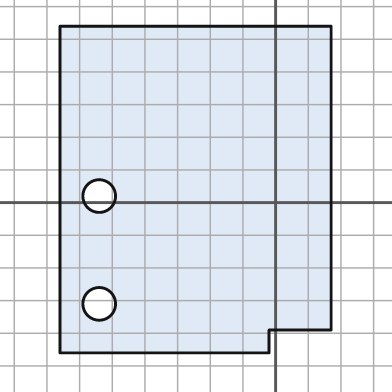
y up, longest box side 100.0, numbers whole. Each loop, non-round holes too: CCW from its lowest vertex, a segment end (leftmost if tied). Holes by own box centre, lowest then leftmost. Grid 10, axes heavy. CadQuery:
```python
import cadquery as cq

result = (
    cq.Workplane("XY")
    .moveTo(-66.0, -46.0)
    .lineTo(-2.0, -46.0)
    .lineTo(-2.0, -39.0)
    .lineTo(17.0, -39.0)
    .lineTo(17.0, 54.0)
    .lineTo(-66.0, 54.0)
    .close()
    .moveTo(-54.0, -31.0)
    .circle(5.0)
    .moveTo(-54.0, 2.0)
    .circle(5.0)
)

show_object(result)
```